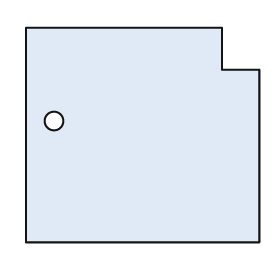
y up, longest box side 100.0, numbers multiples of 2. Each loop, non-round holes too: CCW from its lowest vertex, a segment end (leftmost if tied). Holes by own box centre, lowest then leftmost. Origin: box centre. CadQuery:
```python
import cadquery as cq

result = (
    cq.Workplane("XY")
    .moveTo(-50.0, -46.0)
    .lineTo(50.0, -46.0)
    .lineTo(50.0, 28.0)
    .lineTo(34.0, 28.0)
    .lineTo(34.0, 46.0)
    .lineTo(-50.0, 46.0)
    .close()
    .moveTo(-38.0, 6.0)
    .circle(4.0)
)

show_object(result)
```